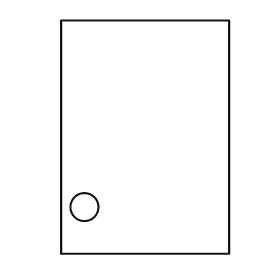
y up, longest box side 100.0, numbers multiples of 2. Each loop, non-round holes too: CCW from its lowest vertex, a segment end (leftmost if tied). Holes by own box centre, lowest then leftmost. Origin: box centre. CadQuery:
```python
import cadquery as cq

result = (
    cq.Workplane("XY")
    .moveTo(-36.0, -50.0)
    .lineTo(36.0, -50.0)
    .lineTo(36.0, 50.0)
    .lineTo(-36.0, 50.0)
    .close()
    .moveTo(-26.0, -30.0)
    .circle(6.0)
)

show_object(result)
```